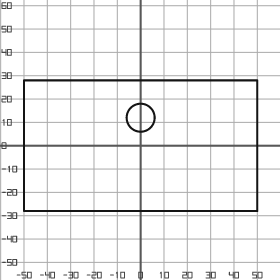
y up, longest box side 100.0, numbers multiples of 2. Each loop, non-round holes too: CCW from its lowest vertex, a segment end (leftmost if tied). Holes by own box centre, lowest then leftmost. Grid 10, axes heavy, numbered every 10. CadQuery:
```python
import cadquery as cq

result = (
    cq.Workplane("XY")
    .moveTo(-50.0, -28.0)
    .lineTo(50.0, -28.0)
    .lineTo(50.0, 28.0)
    .lineTo(-50.0, 28.0)
    .close()
    .moveTo(0.0, 12.0)
    .circle(6.0)
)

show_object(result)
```